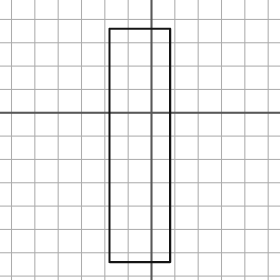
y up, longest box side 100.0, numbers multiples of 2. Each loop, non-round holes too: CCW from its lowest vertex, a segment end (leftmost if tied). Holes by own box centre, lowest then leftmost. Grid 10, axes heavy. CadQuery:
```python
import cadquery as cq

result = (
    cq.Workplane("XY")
    .moveTo(-18.0, -64.0)
    .lineTo(8.0, -64.0)
    .lineTo(8.0, 36.0)
    .lineTo(-18.0, 36.0)
    .close()
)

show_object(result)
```